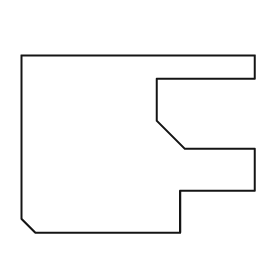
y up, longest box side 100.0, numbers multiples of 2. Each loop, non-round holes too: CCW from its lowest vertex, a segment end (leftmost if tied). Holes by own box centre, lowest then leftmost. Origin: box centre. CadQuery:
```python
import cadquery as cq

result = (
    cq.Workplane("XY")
    .moveTo(-44.0, -38.0)
    .lineTo(18.0, -38.0)
    .lineTo(18.0, -20.0)
    .lineTo(50.0, -20.0)
    .lineTo(50.0, -2.0)
    .lineTo(20.0, -2.0)
    .lineTo(8.0, 10.0)
    .lineTo(8.0, 28.0)
    .lineTo(50.0, 28.0)
    .lineTo(50.0, 38.0)
    .lineTo(-50.0, 38.0)
    .lineTo(-50.0, -32.0)
    .close()
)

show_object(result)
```